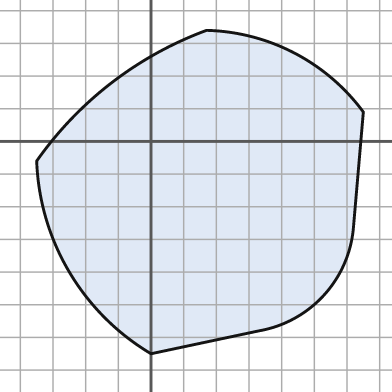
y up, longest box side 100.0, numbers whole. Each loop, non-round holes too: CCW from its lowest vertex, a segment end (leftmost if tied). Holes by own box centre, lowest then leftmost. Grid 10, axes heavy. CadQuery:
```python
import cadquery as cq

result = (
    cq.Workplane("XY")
    .moveTo(0.0, -65.0)
    .lineTo(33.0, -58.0)
    .threePointArc((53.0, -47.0), (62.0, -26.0))
    .lineTo(65.0, 9.0)
    .threePointArc((44.0, 27.0), (17.0, 34.0))
    .threePointArc((-12.0, 18.0), (-35.0, -6.0))
    .threePointArc((-25.0, -40.0), (0.0, -65.0))
    .close()
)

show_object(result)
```